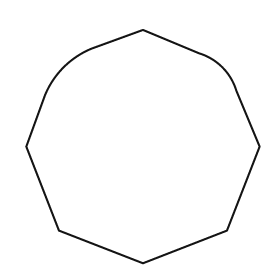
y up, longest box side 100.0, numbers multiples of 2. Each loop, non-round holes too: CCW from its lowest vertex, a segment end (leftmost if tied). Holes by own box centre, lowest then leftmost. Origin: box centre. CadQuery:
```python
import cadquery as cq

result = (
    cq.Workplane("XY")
    .moveTo(0.0, -50.0)
    .lineTo(36.0, -36.0)
    .lineTo(50.0, 0.0)
    .lineTo(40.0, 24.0)
    .threePointArc((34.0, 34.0), (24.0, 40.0))
    .lineTo(0.0, 50.0)
    .lineTo(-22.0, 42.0)
    .threePointArc((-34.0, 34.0), (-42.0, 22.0))
    .lineTo(-50.0, 0.0)
    .lineTo(-36.0, -36.0)
    .close()
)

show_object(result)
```